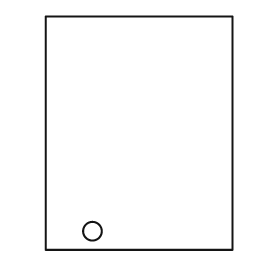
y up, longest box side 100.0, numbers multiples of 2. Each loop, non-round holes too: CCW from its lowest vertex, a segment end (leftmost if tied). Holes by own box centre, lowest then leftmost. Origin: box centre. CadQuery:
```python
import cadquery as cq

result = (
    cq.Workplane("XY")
    .moveTo(-40.0, -50.0)
    .lineTo(40.0, -50.0)
    .lineTo(40.0, 50.0)
    .lineTo(-40.0, 50.0)
    .close()
    .moveTo(-20.0, -42.0)
    .circle(4.0)
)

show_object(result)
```